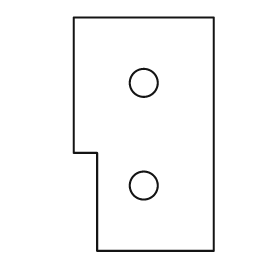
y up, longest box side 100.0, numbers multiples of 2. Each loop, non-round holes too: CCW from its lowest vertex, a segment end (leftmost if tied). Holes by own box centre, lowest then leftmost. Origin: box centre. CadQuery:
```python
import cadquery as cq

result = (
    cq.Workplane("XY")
    .moveTo(-20.0, -50.0)
    .lineTo(30.0, -50.0)
    .lineTo(30.0, 50.0)
    .lineTo(-30.0, 50.0)
    .lineTo(-30.0, -8.0)
    .lineTo(-20.0, -8.0)
    .close()
    .moveTo(0.0, -22.0)
    .circle(6.0)
    .moveTo(0.0, 22.0)
    .circle(6.0)
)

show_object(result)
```